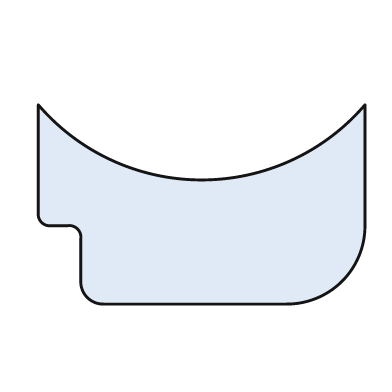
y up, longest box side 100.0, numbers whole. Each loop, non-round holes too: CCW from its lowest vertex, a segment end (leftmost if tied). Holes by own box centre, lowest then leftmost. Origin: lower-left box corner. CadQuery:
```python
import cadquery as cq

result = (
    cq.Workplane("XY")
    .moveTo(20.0, 0.0)
    .lineTo(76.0, 0.0)
    .threePointArc((93.0, 7.0), (100.0, 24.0))
    .lineTo(100.0, 61.0)
    .threePointArc((50.0, 38.0), (0.0, 61.0))
    .lineTo(0.0, 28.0)
    .threePointArc((1.0, 25.0), (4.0, 24.0))
    .lineTo(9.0, 24.0)
    .threePointArc((12.0, 23.0), (13.0, 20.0))
    .lineTo(13.0, 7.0)
    .threePointArc((15.0, 2.0), (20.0, 0.0))
    .close()
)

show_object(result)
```